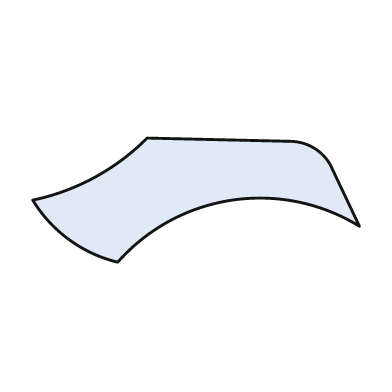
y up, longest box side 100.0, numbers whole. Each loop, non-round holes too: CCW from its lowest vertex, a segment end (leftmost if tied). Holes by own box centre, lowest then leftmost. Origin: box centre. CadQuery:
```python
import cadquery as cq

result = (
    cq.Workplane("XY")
    .moveTo(-24.0, -19.0)
    .threePointArc((11.0, 0.0), (50.0, -8.0))
    .lineTo(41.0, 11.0)
    .threePointArc((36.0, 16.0), (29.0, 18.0))
    .lineTo(-15.0, 19.0)
    .threePointArc((-31.0, 7.0), (-50.0, 0.0))
    .threePointArc((-39.0, -12.0), (-24.0, -19.0))
    .close()
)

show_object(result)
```